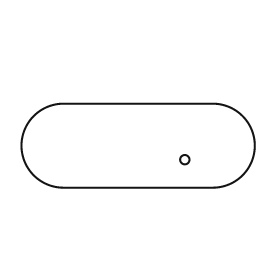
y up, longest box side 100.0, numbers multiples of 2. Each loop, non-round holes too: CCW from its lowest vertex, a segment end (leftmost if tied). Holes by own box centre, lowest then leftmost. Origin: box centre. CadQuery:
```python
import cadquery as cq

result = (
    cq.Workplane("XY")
    .moveTo(-32.0, -18.0)
    .lineTo(32.0, -18.0)
    .threePointArc((50.0, 0.0), (32.0, 18.0))
    .lineTo(-32.0, 18.0)
    .threePointArc((-50.0, 0.0), (-32.0, -18.0))
    .close()
    .moveTo(20.0, -6.0)
    .circle(2.0)
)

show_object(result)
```